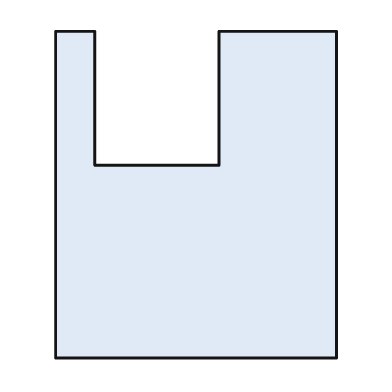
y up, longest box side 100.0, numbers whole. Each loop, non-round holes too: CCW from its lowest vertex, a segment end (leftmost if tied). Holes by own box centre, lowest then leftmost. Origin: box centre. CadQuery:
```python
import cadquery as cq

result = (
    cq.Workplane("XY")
    .moveTo(-43.0, -50.0)
    .lineTo(43.0, -50.0)
    .lineTo(43.0, 50.0)
    .lineTo(7.0, 50.0)
    .lineTo(7.0, 9.0)
    .lineTo(-31.0, 9.0)
    .lineTo(-31.0, 50.0)
    .lineTo(-43.0, 50.0)
    .close()
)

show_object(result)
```